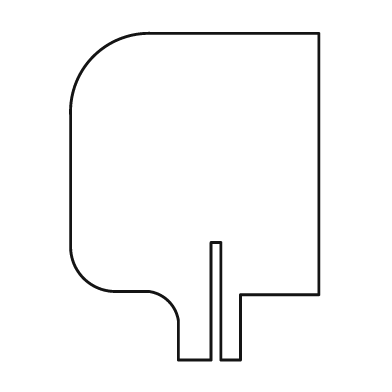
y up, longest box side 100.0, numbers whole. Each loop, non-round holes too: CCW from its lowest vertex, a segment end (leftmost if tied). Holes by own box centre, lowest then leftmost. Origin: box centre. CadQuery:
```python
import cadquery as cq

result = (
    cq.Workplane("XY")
    .moveTo(-5.0, -50.0)
    .lineTo(5.0, -50.0)
    .lineTo(5.0, -14.0)
    .lineTo(8.0, -14.0)
    .lineTo(8.0, -50.0)
    .lineTo(14.0, -50.0)
    .lineTo(14.0, -30.0)
    .lineTo(38.0, -30.0)
    .lineTo(38.0, 50.0)
    .lineTo(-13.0, 50.0)
    .threePointArc((-31.0, 43.0), (-38.0, 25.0))
    .lineTo(-38.0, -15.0)
    .threePointArc((-34.0, -25.0), (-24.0, -29.0))
    .lineTo(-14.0, -29.0)
    .threePointArc((-8.0, -32.0), (-5.0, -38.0))
    .close()
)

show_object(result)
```